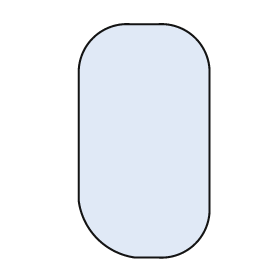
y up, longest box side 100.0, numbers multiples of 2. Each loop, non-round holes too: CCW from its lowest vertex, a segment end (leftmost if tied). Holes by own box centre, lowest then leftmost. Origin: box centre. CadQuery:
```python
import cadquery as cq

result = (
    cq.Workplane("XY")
    .moveTo(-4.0, -50.0)
    .lineTo(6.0, -50.0)
    .threePointArc((22.0, -44.0), (28.0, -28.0))
    .lineTo(28.0, 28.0)
    .threePointArc((22.0, 44.0), (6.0, 50.0))
    .lineTo(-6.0, 50.0)
    .threePointArc((-22.0, 44.0), (-28.0, 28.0))
    .lineTo(-28.0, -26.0)
    .threePointArc((-20.0, -42.0), (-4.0, -50.0))
    .close()
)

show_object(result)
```